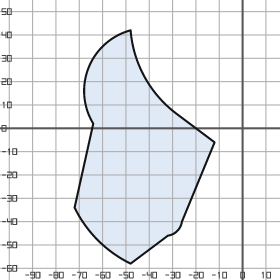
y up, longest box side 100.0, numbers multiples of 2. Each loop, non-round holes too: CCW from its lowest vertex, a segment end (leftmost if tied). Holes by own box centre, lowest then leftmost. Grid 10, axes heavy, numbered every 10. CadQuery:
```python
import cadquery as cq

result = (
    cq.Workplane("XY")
    .moveTo(-48.0, -58.0)
    .lineTo(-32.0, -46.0)
    .threePointArc((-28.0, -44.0), (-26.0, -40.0))
    .lineTo(-12.0, -6.0)
    .lineTo(-28.0, 6.0)
    .threePointArc((-42.0, 22.0), (-48.0, 42.0))
    .threePointArc((-66.0, 26.0), (-64.0, 2.0))
    .lineTo(-72.0, -34.0)
    .threePointArc((-62.0, -48.0), (-48.0, -58.0))
    .close()
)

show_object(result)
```